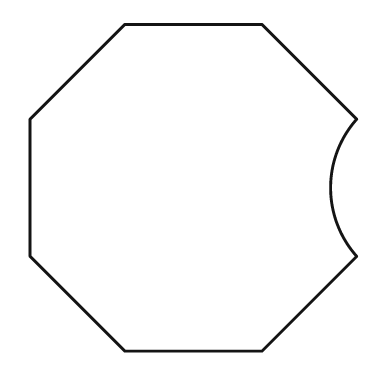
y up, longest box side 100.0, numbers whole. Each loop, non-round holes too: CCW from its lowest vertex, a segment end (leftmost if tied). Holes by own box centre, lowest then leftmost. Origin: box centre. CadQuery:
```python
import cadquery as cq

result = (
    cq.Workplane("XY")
    .moveTo(-21.0, -50.0)
    .lineTo(21.0, -50.0)
    .lineTo(50.0, -21.0)
    .threePointArc((42.0, 0.0), (50.0, 21.0))
    .lineTo(21.0, 50.0)
    .lineTo(-21.0, 50.0)
    .lineTo(-50.0, 21.0)
    .lineTo(-50.0, -21.0)
    .close()
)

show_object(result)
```